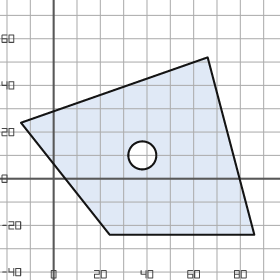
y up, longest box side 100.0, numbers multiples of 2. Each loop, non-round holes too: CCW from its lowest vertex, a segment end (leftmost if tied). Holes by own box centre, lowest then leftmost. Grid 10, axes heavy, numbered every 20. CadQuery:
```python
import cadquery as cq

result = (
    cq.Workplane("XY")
    .moveTo(24.0, -24.0)
    .lineTo(86.0, -24.0)
    .lineTo(66.0, 52.0)
    .lineTo(-14.0, 24.0)
    .close()
    .moveTo(38.0, 10.0)
    .circle(6.0)
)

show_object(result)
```